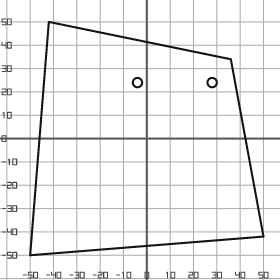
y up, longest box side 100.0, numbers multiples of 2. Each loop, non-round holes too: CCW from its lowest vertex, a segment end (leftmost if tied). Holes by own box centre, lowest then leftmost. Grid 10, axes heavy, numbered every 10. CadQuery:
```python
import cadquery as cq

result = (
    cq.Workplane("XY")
    .moveTo(-50.0, -50.0)
    .lineTo(50.0, -42.0)
    .lineTo(36.0, 34.0)
    .lineTo(-42.0, 50.0)
    .close()
    .moveTo(-4.0, 24.0)
    .circle(2.0)
    .moveTo(28.0, 24.0)
    .circle(2.0)
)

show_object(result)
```